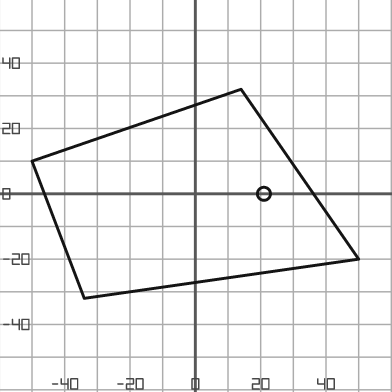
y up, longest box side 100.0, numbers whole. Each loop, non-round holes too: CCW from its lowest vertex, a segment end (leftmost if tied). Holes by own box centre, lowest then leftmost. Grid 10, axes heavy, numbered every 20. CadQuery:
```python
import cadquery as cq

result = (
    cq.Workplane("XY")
    .moveTo(-34.0, -32.0)
    .lineTo(50.0, -20.0)
    .lineTo(14.0, 32.0)
    .lineTo(-50.0, 10.0)
    .close()
    .moveTo(21.0, 0.0)
    .circle(2.0)
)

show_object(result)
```